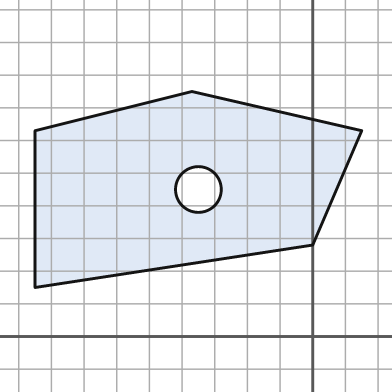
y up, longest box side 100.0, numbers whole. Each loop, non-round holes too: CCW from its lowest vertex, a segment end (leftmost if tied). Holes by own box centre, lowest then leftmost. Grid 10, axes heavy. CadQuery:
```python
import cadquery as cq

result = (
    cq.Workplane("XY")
    .moveTo(-85.0, 15.0)
    .lineTo(0.0, 28.0)
    .lineTo(15.0, 63.0)
    .lineTo(-37.0, 75.0)
    .lineTo(-85.0, 63.0)
    .close()
    .moveTo(-35.0, 45.0)
    .circle(7.0)
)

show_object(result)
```